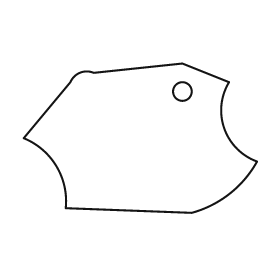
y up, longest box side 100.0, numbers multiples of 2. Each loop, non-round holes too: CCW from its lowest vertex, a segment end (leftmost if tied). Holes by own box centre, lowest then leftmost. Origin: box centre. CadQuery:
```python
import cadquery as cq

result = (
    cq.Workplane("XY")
    .moveTo(22.0, -32.0)
    .threePointArc((38.0, -24.0), (50.0, -10.0))
    .threePointArc((36.0, 4.0), (38.0, 24.0))
    .lineTo(18.0, 32.0)
    .lineTo(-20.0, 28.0)
    .threePointArc((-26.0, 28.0), (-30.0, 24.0))
    .lineTo(-50.0, 0.0)
    .threePointArc((-36.0, -12.0), (-32.0, -30.0))
    .close()
    .moveTo(18.0, 20.0)
    .circle(4.0)
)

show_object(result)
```